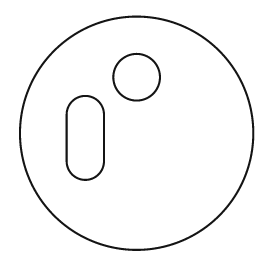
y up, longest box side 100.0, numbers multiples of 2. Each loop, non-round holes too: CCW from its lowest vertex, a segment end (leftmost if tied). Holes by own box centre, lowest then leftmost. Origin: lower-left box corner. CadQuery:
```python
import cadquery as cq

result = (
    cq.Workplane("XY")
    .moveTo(50.0, 50.0)
    .circle(50.0)
    .moveTo(20.0, 38.0)
    .threePointArc((28.0, 30.0), (36.0, 38.0))
    .lineTo(36.0, 58.0)
    .threePointArc((28.0, 66.0), (20.0, 58.0))
    .close()
    .moveTo(50.0, 74.0)
    .circle(10.0)
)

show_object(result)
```